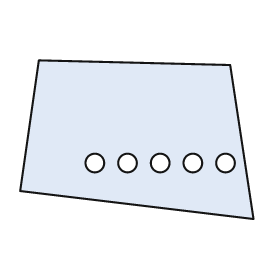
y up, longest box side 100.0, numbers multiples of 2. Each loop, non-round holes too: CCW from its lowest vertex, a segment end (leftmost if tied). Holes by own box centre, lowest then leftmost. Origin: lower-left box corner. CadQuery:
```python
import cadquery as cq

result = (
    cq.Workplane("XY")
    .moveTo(100.0, 0.0)
    .lineTo(90.0, 66.0)
    .lineTo(8.0, 68.0)
    .lineTo(0.0, 12.0)
    .close()
    .moveTo(32.0, 24.0)
    .circle(4.0)
    .moveTo(46.0, 24.0)
    .circle(4.0)
    .moveTo(60.0, 24.0)
    .circle(4.0)
    .moveTo(74.0, 24.0)
    .circle(4.0)
    .moveTo(88.0, 24.0)
    .circle(4.0)
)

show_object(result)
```